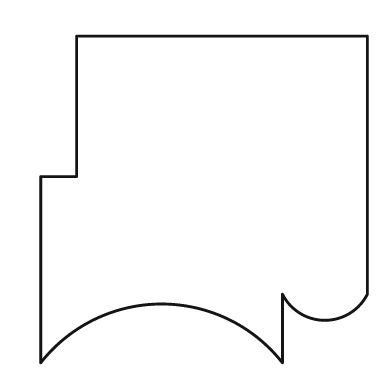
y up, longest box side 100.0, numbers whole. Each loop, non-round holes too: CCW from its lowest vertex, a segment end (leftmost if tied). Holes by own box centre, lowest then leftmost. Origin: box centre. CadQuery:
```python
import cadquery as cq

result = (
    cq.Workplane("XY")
    .moveTo(-50.0, -50.0)
    .threePointArc((-13.0, -32.0), (24.0, -50.0))
    .lineTo(24.0, -29.0)
    .threePointArc((37.0, -37.0), (50.0, -29.0))
    .lineTo(50.0, 50.0)
    .lineTo(-39.0, 50.0)
    .lineTo(-39.0, 7.0)
    .lineTo(-50.0, 7.0)
    .close()
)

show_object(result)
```